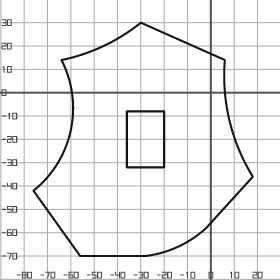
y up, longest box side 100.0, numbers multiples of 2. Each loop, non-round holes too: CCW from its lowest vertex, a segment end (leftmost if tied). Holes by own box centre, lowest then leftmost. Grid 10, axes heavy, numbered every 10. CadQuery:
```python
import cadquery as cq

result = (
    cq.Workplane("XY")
    .moveTo(-56.0, -70.0)
    .lineTo(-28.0, -70.0)
    .threePointArc((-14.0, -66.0), (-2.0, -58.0))
    .lineTo(18.0, -36.0)
    .threePointArc((8.0, -12.0), (6.0, 14.0))
    .lineTo(-30.0, 30.0)
    .threePointArc((-46.0, 20.0), (-64.0, 14.0))
    .threePointArc((-60.0, -16.0), (-76.0, -42.0))
    .close()
    .moveTo(-36.0, -32.0)
    .lineTo(-20.0, -32.0)
    .lineTo(-20.0, -8.0)
    .lineTo(-36.0, -8.0)
    .close()
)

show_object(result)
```